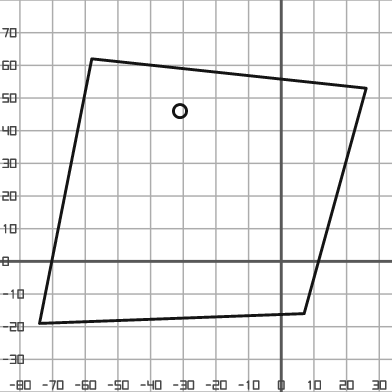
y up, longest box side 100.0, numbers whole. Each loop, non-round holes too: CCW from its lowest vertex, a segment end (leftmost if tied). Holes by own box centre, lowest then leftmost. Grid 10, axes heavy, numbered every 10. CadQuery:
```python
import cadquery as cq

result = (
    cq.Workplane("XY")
    .moveTo(-74.0, -19.0)
    .lineTo(7.0, -16.0)
    .lineTo(26.0, 53.0)
    .lineTo(-58.0, 62.0)
    .close()
    .moveTo(-31.0, 46.0)
    .circle(2.0)
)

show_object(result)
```